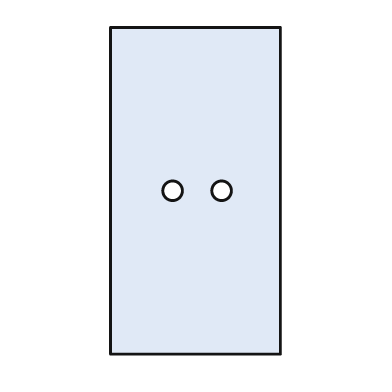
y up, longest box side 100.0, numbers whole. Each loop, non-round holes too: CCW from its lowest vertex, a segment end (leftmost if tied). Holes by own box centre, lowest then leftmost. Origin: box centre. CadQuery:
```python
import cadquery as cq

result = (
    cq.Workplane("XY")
    .moveTo(-26.0, -50.0)
    .lineTo(26.0, -50.0)
    .lineTo(26.0, 50.0)
    .lineTo(-26.0, 50.0)
    .close()
    .moveTo(-7.0, 0.0)
    .circle(3.0)
    .moveTo(8.0, 0.0)
    .circle(3.0)
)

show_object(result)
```